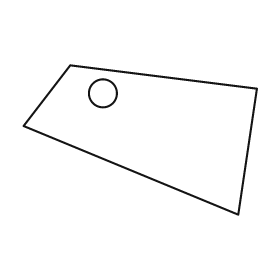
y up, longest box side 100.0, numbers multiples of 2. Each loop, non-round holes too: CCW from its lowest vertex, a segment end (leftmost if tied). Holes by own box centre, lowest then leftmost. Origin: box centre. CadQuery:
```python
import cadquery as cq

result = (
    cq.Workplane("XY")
    .moveTo(42.0, -32.0)
    .lineTo(50.0, 22.0)
    .lineTo(-30.0, 32.0)
    .lineTo(-50.0, 6.0)
    .close()
    .moveTo(-16.0, 20.0)
    .circle(6.0)
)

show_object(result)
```